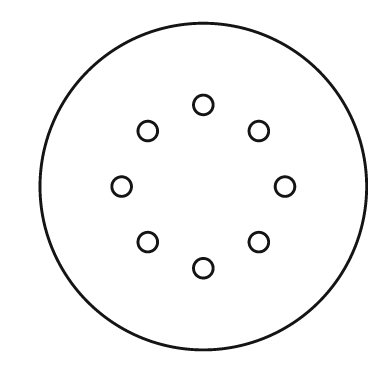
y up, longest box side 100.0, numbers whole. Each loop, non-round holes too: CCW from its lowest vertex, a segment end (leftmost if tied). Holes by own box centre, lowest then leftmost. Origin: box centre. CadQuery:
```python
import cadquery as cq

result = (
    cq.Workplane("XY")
    .moveTo(0.0, 0.0)
    .circle(50.0)
    .moveTo(0.0, -25.0)
    .circle(3.0)
    .moveTo(-17.0, -17.0)
    .circle(3.0)
    .moveTo(17.0, -17.0)
    .circle(3.0)
    .moveTo(-25.0, 0.0)
    .circle(3.0)
    .moveTo(25.0, 0.0)
    .circle(3.0)
    .moveTo(-17.0, 17.0)
    .circle(3.0)
    .moveTo(17.0, 17.0)
    .circle(3.0)
    .moveTo(0.0, 25.0)
    .circle(3.0)
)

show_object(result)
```